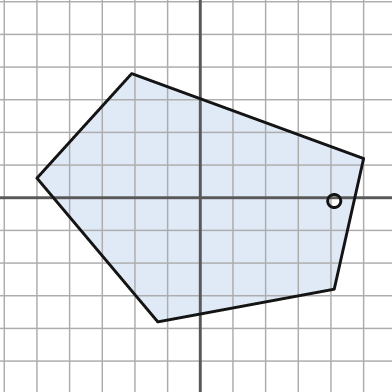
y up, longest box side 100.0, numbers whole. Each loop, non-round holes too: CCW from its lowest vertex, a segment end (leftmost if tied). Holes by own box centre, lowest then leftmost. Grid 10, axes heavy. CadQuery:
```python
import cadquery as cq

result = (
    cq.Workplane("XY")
    .moveTo(-13.0, -38.0)
    .lineTo(41.0, -28.0)
    .lineTo(50.0, 12.0)
    .lineTo(-21.0, 38.0)
    .lineTo(-50.0, 6.0)
    .close()
    .moveTo(41.0, -1.0)
    .circle(2.0)
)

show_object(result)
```